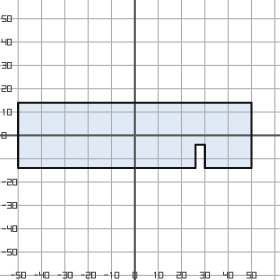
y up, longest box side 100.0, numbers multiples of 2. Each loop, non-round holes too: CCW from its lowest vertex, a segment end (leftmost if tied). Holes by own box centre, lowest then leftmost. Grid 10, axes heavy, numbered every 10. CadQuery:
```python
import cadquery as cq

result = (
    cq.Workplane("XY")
    .moveTo(-50.0, -14.0)
    .lineTo(26.0, -14.0)
    .lineTo(26.0, -4.0)
    .lineTo(30.0, -4.0)
    .lineTo(30.0, -14.0)
    .lineTo(50.0, -14.0)
    .lineTo(50.0, 14.0)
    .lineTo(-50.0, 14.0)
    .close()
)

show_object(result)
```